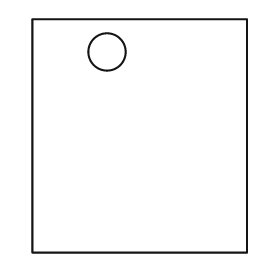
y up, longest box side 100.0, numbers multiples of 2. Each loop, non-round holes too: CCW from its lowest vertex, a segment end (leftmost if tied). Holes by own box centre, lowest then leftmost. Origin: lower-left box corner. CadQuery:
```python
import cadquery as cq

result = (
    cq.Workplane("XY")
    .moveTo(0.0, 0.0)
    .lineTo(92.0, 0.0)
    .lineTo(92.0, 100.0)
    .lineTo(0.0, 100.0)
    .close()
    .moveTo(32.0, 86.0)
    .circle(8.0)
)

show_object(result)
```